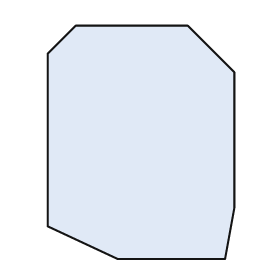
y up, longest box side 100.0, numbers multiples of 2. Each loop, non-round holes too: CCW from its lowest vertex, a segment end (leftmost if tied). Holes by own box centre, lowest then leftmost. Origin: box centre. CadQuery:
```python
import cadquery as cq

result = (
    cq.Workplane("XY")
    .moveTo(-10.0, -50.0)
    .lineTo(36.0, -50.0)
    .lineTo(40.0, -28.0)
    .lineTo(40.0, 30.0)
    .lineTo(20.0, 50.0)
    .lineTo(-28.0, 50.0)
    .lineTo(-40.0, 38.0)
    .lineTo(-40.0, -36.0)
    .close()
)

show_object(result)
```